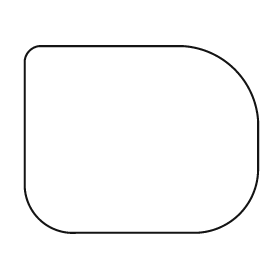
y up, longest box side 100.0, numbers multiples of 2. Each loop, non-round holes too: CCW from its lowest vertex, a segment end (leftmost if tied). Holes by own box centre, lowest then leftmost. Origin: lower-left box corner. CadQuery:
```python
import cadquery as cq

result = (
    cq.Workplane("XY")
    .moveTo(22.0, 0.0)
    .lineTo(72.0, 0.0)
    .threePointArc((92.0, 8.0), (100.0, 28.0))
    .lineTo(100.0, 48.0)
    .threePointArc((90.0, 70.0), (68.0, 80.0))
    .lineTo(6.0, 80.0)
    .threePointArc((2.0, 78.0), (0.0, 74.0))
    .lineTo(0.0, 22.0)
    .threePointArc((6.0, 6.0), (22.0, 0.0))
    .close()
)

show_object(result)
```